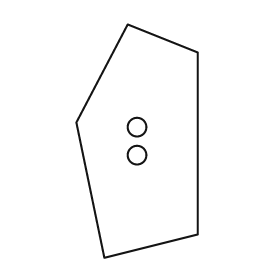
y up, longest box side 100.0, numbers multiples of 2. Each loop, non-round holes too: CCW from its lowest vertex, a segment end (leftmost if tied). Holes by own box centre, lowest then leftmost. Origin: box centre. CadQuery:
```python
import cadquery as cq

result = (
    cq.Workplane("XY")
    .moveTo(-14.0, -50.0)
    .lineTo(26.0, -40.0)
    .lineTo(26.0, 38.0)
    .lineTo(-4.0, 50.0)
    .lineTo(-26.0, 8.0)
    .close()
    .moveTo(0.0, -6.0)
    .circle(4.0)
    .moveTo(0.0, 6.0)
    .circle(4.0)
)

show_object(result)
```